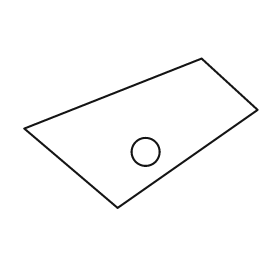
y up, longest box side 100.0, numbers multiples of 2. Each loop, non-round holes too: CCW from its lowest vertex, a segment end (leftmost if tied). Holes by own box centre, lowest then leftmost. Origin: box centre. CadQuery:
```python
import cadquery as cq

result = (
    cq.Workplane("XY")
    .moveTo(-10.0, -32.0)
    .lineTo(50.0, 10.0)
    .lineTo(26.0, 32.0)
    .lineTo(-50.0, 2.0)
    .close()
    .moveTo(2.0, -8.0)
    .circle(6.0)
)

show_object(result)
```